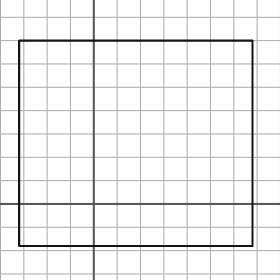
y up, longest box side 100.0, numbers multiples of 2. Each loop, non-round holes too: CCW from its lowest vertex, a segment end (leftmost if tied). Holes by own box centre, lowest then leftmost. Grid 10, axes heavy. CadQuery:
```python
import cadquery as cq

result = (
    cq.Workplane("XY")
    .moveTo(-32.0, -18.0)
    .lineTo(68.0, -18.0)
    .lineTo(68.0, 70.0)
    .lineTo(-32.0, 70.0)
    .close()
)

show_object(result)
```